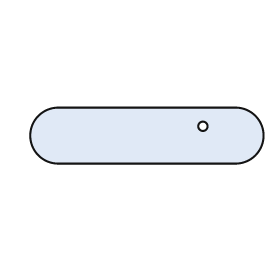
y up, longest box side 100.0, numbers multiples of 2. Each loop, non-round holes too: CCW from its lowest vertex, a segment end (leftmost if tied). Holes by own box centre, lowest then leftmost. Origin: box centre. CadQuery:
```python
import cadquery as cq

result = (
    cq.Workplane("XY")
    .moveTo(-38.0, -12.0)
    .lineTo(38.0, -12.0)
    .threePointArc((50.0, 0.0), (38.0, 12.0))
    .lineTo(-38.0, 12.0)
    .threePointArc((-50.0, 0.0), (-38.0, -12.0))
    .close()
    .moveTo(24.0, 4.0)
    .circle(2.0)
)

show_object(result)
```